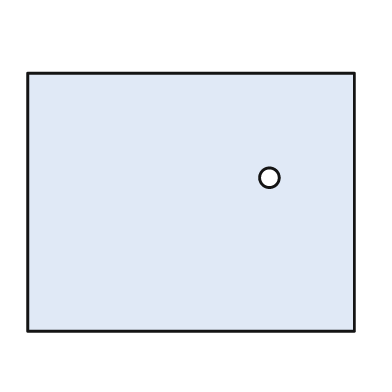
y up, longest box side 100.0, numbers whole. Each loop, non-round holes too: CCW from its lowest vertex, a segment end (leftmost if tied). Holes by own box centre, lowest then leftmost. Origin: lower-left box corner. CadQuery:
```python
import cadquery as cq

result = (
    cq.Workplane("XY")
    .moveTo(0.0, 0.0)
    .lineTo(100.0, 0.0)
    .lineTo(100.0, 79.0)
    .lineTo(0.0, 79.0)
    .close()
    .moveTo(74.0, 47.0)
    .circle(3.0)
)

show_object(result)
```